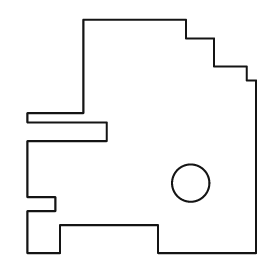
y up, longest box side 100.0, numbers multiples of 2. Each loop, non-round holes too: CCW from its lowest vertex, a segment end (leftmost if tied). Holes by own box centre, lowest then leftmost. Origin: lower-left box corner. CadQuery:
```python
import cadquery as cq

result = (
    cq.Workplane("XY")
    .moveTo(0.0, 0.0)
    .lineTo(14.0, 0.0)
    .lineTo(14.0, 12.0)
    .lineTo(56.0, 12.0)
    .lineTo(56.0, 0.0)
    .lineTo(98.0, 0.0)
    .lineTo(98.0, 74.0)
    .lineTo(94.0, 74.0)
    .lineTo(94.0, 80.0)
    .lineTo(80.0, 80.0)
    .lineTo(80.0, 92.0)
    .lineTo(68.0, 92.0)
    .lineTo(68.0, 100.0)
    .lineTo(24.0, 100.0)
    .lineTo(24.0, 60.0)
    .lineTo(0.0, 60.0)
    .lineTo(0.0, 56.0)
    .lineTo(34.0, 56.0)
    .lineTo(34.0, 48.0)
    .lineTo(0.0, 48.0)
    .lineTo(0.0, 24.0)
    .lineTo(12.0, 24.0)
    .lineTo(12.0, 18.0)
    .lineTo(0.0, 18.0)
    .close()
    .moveTo(70.0, 30.0)
    .circle(8.0)
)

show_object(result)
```